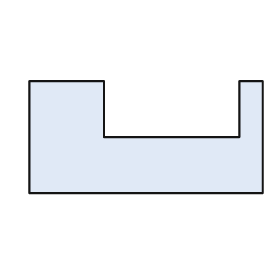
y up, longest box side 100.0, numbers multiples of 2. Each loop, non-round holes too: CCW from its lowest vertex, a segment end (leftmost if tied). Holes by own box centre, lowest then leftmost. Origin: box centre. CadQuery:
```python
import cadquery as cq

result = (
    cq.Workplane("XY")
    .moveTo(-50.0, -24.0)
    .lineTo(50.0, -24.0)
    .lineTo(50.0, 24.0)
    .lineTo(40.0, 24.0)
    .lineTo(40.0, 0.0)
    .lineTo(-18.0, 0.0)
    .lineTo(-18.0, 24.0)
    .lineTo(-50.0, 24.0)
    .close()
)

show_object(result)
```